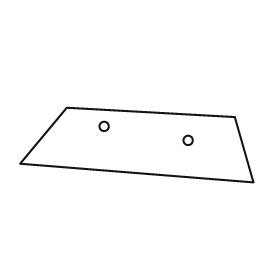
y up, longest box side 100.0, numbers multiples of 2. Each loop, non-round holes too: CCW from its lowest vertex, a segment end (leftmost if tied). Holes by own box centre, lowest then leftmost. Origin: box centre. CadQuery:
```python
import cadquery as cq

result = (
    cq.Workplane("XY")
    .moveTo(50.0, -16.0)
    .lineTo(42.0, 12.0)
    .lineTo(-30.0, 16.0)
    .lineTo(-50.0, -8.0)
    .close()
    .moveTo(22.0, 2.0)
    .circle(2.0)
    .moveTo(-14.0, 8.0)
    .circle(2.0)
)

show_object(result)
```